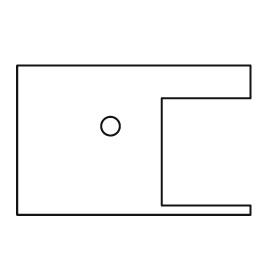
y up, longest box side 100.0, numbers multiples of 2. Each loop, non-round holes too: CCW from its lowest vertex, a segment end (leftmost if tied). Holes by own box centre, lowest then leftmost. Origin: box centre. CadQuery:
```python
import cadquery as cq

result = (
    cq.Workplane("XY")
    .moveTo(-50.0, -32.0)
    .lineTo(50.0, -32.0)
    .lineTo(50.0, -28.0)
    .lineTo(12.0, -28.0)
    .lineTo(12.0, 18.0)
    .lineTo(50.0, 18.0)
    .lineTo(50.0, 32.0)
    .lineTo(-50.0, 32.0)
    .close()
    .moveTo(-10.0, 6.0)
    .circle(4.0)
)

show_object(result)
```